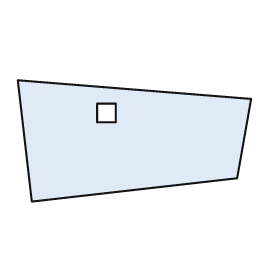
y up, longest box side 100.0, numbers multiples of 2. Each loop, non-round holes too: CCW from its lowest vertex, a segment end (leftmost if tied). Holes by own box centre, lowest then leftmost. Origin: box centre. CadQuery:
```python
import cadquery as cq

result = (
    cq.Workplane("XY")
    .moveTo(-44.0, -26.0)
    .lineTo(44.0, -16.0)
    .lineTo(50.0, 18.0)
    .lineTo(-50.0, 26.0)
    .close()
    .moveTo(-16.0, 8.0)
    .lineTo(-8.0, 8.0)
    .lineTo(-8.0, 16.0)
    .lineTo(-16.0, 16.0)
    .close()
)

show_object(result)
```